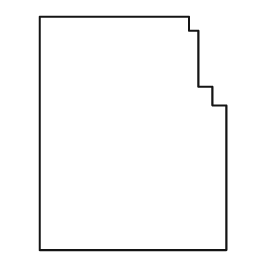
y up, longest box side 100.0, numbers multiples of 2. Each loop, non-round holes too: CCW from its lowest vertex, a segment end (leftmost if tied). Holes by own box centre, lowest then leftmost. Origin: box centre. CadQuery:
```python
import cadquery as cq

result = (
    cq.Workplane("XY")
    .moveTo(-40.0, -50.0)
    .lineTo(40.0, -50.0)
    .lineTo(40.0, 12.0)
    .lineTo(34.0, 12.0)
    .lineTo(34.0, 20.0)
    .lineTo(28.0, 20.0)
    .lineTo(28.0, 44.0)
    .lineTo(24.0, 44.0)
    .lineTo(24.0, 50.0)
    .lineTo(-40.0, 50.0)
    .close()
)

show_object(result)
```